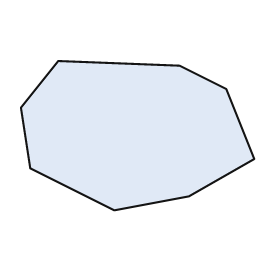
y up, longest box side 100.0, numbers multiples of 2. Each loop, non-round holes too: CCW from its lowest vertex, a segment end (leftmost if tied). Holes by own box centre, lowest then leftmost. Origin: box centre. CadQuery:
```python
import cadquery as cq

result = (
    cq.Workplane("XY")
    .moveTo(-10.0, -32.0)
    .lineTo(22.0, -26.0)
    .lineTo(50.0, -10.0)
    .lineTo(38.0, 20.0)
    .lineTo(18.0, 30.0)
    .lineTo(-34.0, 32.0)
    .lineTo(-50.0, 12.0)
    .lineTo(-46.0, -14.0)
    .close()
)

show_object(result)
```